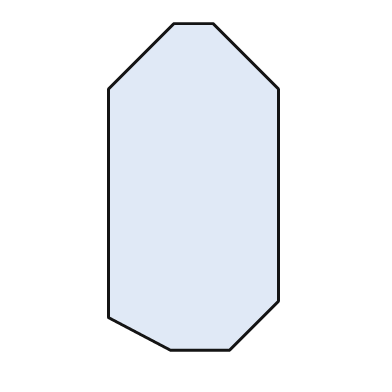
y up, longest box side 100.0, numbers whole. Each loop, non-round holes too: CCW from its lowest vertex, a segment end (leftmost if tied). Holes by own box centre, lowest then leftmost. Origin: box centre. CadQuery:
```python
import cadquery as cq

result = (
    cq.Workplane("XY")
    .moveTo(-7.0, -50.0)
    .lineTo(11.0, -50.0)
    .lineTo(26.0, -35.0)
    .lineTo(26.0, 30.0)
    .lineTo(6.0, 50.0)
    .lineTo(-6.0, 50.0)
    .lineTo(-26.0, 30.0)
    .lineTo(-26.0, -40.0)
    .close()
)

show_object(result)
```